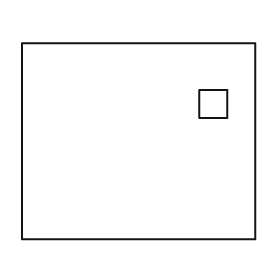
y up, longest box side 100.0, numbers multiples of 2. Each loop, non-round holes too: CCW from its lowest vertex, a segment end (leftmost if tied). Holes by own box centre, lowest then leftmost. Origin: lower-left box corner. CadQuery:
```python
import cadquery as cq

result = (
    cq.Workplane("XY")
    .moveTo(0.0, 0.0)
    .lineTo(100.0, 0.0)
    .lineTo(100.0, 84.0)
    .lineTo(0.0, 84.0)
    .close()
    .moveTo(76.0, 52.0)
    .lineTo(88.0, 52.0)
    .lineTo(88.0, 64.0)
    .lineTo(76.0, 64.0)
    .close()
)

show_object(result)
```